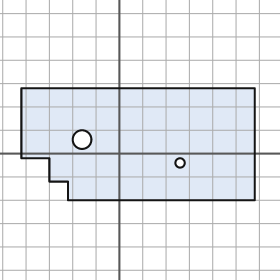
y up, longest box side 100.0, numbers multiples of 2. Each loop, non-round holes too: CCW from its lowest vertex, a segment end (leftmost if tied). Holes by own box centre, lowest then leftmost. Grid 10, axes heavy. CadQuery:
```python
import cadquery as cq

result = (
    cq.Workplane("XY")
    .moveTo(-22.0, -20.0)
    .lineTo(58.0, -20.0)
    .lineTo(58.0, 28.0)
    .lineTo(-42.0, 28.0)
    .lineTo(-42.0, -2.0)
    .lineTo(-30.0, -2.0)
    .lineTo(-30.0, -12.0)
    .lineTo(-22.0, -12.0)
    .close()
    .moveTo(26.0, -4.0)
    .circle(2.0)
    .moveTo(-16.0, 6.0)
    .circle(4.0)
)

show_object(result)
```